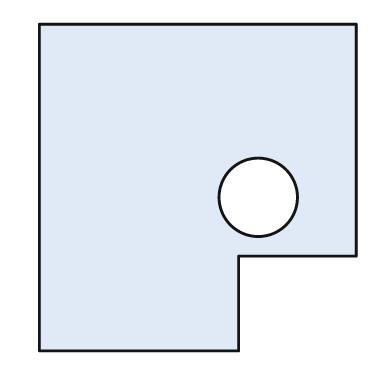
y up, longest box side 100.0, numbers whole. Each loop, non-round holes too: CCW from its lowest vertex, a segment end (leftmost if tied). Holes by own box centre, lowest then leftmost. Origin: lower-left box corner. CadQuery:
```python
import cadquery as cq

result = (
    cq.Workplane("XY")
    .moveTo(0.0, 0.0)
    .lineTo(61.0, 0.0)
    .lineTo(61.0, 29.0)
    .lineTo(97.0, 29.0)
    .lineTo(97.0, 100.0)
    .lineTo(0.0, 100.0)
    .close()
    .moveTo(67.0, 47.0)
    .circle(12.0)
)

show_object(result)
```